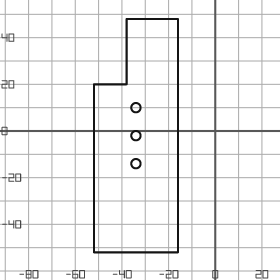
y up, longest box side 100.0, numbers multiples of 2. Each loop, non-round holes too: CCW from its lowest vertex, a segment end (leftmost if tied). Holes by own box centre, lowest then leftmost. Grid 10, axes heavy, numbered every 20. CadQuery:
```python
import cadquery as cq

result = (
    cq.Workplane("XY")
    .moveTo(-52.0, -52.0)
    .lineTo(-16.0, -52.0)
    .lineTo(-16.0, 48.0)
    .lineTo(-38.0, 48.0)
    .lineTo(-38.0, 20.0)
    .lineTo(-52.0, 20.0)
    .close()
    .moveTo(-34.0, -14.0)
    .circle(2.0)
    .moveTo(-34.0, -2.0)
    .circle(2.0)
    .moveTo(-34.0, 10.0)
    .circle(2.0)
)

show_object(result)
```